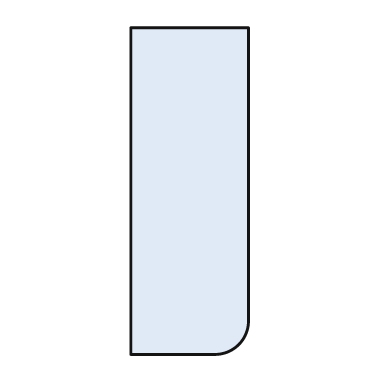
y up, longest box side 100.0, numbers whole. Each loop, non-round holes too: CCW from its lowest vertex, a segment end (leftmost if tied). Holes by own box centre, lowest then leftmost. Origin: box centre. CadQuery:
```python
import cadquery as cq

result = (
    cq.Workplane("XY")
    .moveTo(-18.0, -50.0)
    .lineTo(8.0, -50.0)
    .threePointArc((15.0, -47.0), (18.0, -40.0))
    .lineTo(18.0, 50.0)
    .lineTo(-18.0, 50.0)
    .close()
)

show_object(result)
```